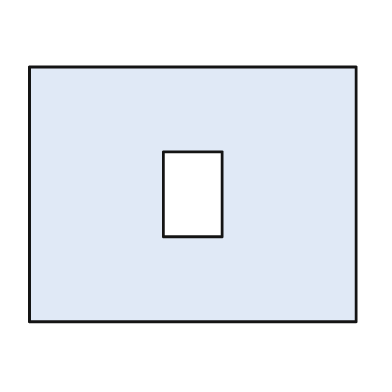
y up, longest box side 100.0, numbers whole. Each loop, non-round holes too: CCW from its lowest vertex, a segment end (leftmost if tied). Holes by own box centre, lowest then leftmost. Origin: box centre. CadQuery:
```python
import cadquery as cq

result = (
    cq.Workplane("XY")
    .moveTo(-50.0, -39.0)
    .lineTo(50.0, -39.0)
    .lineTo(50.0, 39.0)
    .lineTo(-50.0, 39.0)
    .close()
    .moveTo(-9.0, -13.0)
    .lineTo(9.0, -13.0)
    .lineTo(9.0, 13.0)
    .lineTo(-9.0, 13.0)
    .close()
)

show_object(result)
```